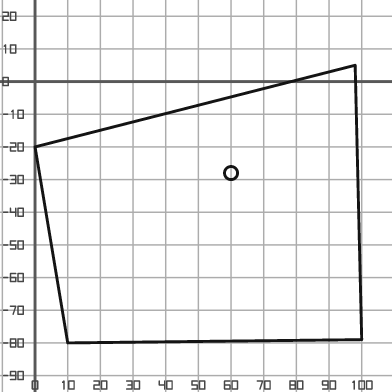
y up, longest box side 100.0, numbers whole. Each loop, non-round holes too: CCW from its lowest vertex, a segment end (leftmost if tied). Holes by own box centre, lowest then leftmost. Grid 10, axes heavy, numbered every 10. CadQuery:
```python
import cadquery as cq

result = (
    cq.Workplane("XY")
    .moveTo(10.0, -80.0)
    .lineTo(100.0, -79.0)
    .lineTo(98.0, 5.0)
    .lineTo(0.0, -20.0)
    .close()
    .moveTo(60.0, -28.0)
    .circle(2.0)
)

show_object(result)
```